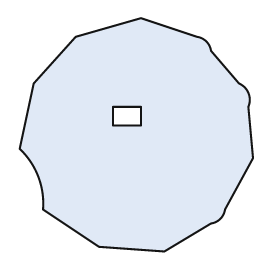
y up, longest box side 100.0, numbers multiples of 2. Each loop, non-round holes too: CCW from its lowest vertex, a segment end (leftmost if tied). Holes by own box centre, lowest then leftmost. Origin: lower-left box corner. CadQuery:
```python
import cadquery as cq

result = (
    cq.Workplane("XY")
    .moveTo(62.0, 0.0)
    .lineTo(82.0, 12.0)
    .threePointArc((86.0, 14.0), (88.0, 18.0))
    .lineTo(100.0, 40.0)
    .lineTo(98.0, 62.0)
    .threePointArc((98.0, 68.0), (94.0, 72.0))
    .lineTo(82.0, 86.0)
    .threePointArc((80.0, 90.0), (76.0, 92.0))
    .lineTo(52.0, 100.0)
    .lineTo(24.0, 92.0)
    .lineTo(6.0, 72.0)
    .lineTo(0.0, 44.0)
    .threePointArc((8.0, 32.0), (10.0, 18.0))
    .lineTo(34.0, 2.0)
    .close()
    .moveTo(40.0, 54.0)
    .lineTo(52.0, 54.0)
    .lineTo(52.0, 62.0)
    .lineTo(40.0, 62.0)
    .close()
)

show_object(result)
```